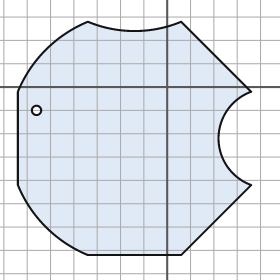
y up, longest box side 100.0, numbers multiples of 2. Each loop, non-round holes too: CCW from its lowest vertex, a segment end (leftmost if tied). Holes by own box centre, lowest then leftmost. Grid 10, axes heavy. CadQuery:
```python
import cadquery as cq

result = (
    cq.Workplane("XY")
    .moveTo(-34.0, -72.0)
    .lineTo(6.0, -72.0)
    .lineTo(36.0, -42.0)
    .threePointArc((22.0, -22.0), (36.0, -2.0))
    .lineTo(6.0, 28.0)
    .threePointArc((-14.0, 24.0), (-34.0, 28.0))
    .threePointArc((-52.0, 16.0), (-64.0, -2.0))
    .lineTo(-64.0, -42.0)
    .threePointArc((-52.0, -60.0), (-34.0, -72.0))
    .close()
    .moveTo(-56.0, -10.0)
    .circle(2.0)
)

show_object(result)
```